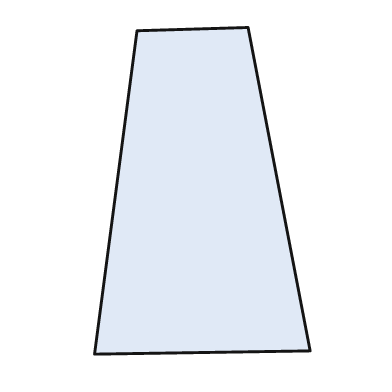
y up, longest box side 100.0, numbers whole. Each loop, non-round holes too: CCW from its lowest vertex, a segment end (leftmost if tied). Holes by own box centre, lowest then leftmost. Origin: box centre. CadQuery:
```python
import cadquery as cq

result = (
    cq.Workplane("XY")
    .moveTo(-33.0, -50.0)
    .lineTo(33.0, -49.0)
    .lineTo(14.0, 50.0)
    .lineTo(-20.0, 49.0)
    .close()
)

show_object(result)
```